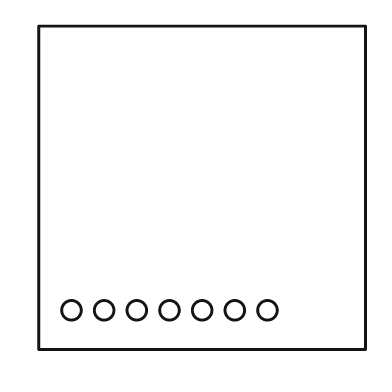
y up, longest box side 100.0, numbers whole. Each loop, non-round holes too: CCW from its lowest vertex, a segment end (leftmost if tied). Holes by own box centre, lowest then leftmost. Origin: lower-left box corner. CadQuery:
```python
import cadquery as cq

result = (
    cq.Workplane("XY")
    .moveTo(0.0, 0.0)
    .lineTo(100.0, 0.0)
    .lineTo(100.0, 99.0)
    .lineTo(0.0, 99.0)
    .close()
    .moveTo(10.0, 12.0)
    .circle(3.0)
    .moveTo(20.0, 12.0)
    .circle(3.0)
    .moveTo(30.0, 12.0)
    .circle(3.0)
    .moveTo(40.0, 12.0)
    .circle(3.0)
    .moveTo(50.0, 12.0)
    .circle(3.0)
    .moveTo(60.0, 12.0)
    .circle(3.0)
    .moveTo(70.0, 12.0)
    .circle(3.0)
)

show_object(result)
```